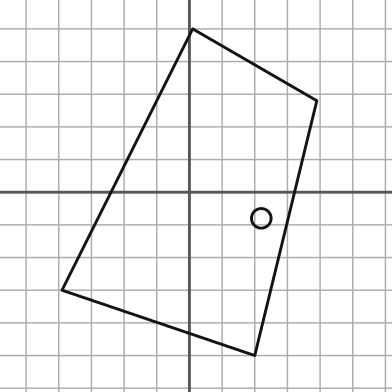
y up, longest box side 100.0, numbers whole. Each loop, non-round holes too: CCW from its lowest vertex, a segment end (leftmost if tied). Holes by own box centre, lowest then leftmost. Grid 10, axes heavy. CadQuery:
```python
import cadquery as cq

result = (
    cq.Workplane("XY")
    .moveTo(20.0, -50.0)
    .lineTo(39.0, 28.0)
    .lineTo(1.0, 50.0)
    .lineTo(-39.0, -30.0)
    .close()
    .moveTo(22.0, -8.0)
    .circle(3.0)
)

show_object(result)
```